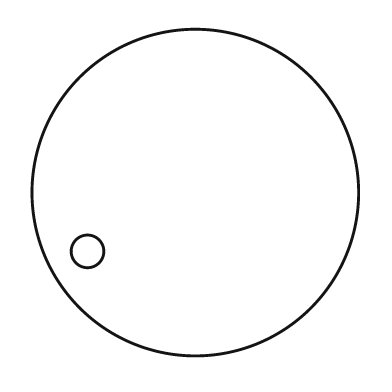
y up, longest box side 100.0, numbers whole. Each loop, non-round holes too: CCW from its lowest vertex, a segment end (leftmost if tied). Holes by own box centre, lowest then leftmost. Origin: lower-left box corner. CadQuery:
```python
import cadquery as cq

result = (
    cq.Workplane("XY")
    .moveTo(50.0, 50.0)
    .circle(50.0)
    .moveTo(17.0, 32.0)
    .circle(5.0)
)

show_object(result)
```